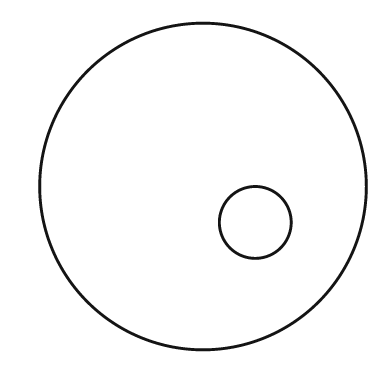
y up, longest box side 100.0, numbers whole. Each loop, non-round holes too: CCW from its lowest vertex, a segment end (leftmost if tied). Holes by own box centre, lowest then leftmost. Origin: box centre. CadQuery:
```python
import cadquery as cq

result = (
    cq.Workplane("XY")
    .moveTo(0.0, 0.0)
    .circle(50.0)
    .moveTo(16.0, -11.0)
    .circle(11.0)
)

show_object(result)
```